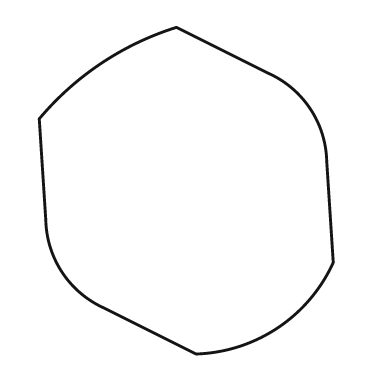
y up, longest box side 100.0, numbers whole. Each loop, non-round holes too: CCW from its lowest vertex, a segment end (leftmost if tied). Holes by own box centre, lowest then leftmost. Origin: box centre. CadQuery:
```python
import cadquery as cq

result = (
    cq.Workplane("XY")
    .moveTo(3.0, -50.0)
    .threePointArc((28.0, -42.0), (45.0, -22.0))
    .lineTo(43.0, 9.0)
    .threePointArc((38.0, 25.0), (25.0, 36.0))
    .lineTo(-3.0, 50.0)
    .threePointArc((-26.0, 39.0), (-45.0, 22.0))
    .lineTo(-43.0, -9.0)
    .threePointArc((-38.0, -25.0), (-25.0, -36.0))
    .close()
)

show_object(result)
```